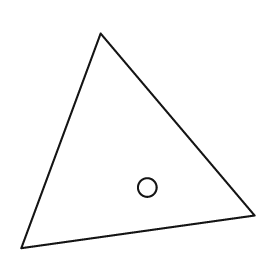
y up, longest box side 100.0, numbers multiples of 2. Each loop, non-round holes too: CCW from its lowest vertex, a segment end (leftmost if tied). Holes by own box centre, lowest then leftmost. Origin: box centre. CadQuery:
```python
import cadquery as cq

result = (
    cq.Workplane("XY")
    .moveTo(-50.0, -46.0)
    .lineTo(50.0, -32.0)
    .lineTo(-16.0, 46.0)
    .close()
    .moveTo(4.0, -20.0)
    .circle(4.0)
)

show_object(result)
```